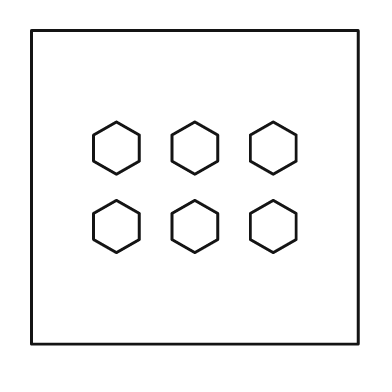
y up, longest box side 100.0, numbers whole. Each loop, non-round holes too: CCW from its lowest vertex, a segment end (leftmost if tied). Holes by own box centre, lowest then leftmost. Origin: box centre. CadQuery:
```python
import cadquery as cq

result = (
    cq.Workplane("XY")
    .moveTo(-50.0, -48.0)
    .lineTo(50.0, -48.0)
    .lineTo(50.0, 48.0)
    .lineTo(-50.0, 48.0)
    .close()
    .moveTo(-24.0, -20.0)
    .lineTo(-17.0, -16.0)
    .lineTo(-17.0, -8.0)
    .lineTo(-24.0, -4.0)
    .lineTo(-31.0, -8.0)
    .lineTo(-31.0, -16.0)
    .close()
    .moveTo(0.0, -20.0)
    .lineTo(7.0, -16.0)
    .lineTo(7.0, -8.0)
    .lineTo(0.0, -4.0)
    .lineTo(-7.0, -8.0)
    .lineTo(-7.0, -16.0)
    .close()
    .moveTo(24.0, -20.0)
    .lineTo(31.0, -16.0)
    .lineTo(31.0, -8.0)
    .lineTo(24.0, -4.0)
    .lineTo(17.0, -8.0)
    .lineTo(17.0, -16.0)
    .close()
    .moveTo(-24.0, 4.0)
    .lineTo(-17.0, 8.0)
    .lineTo(-17.0, 16.0)
    .lineTo(-24.0, 20.0)
    .lineTo(-31.0, 16.0)
    .lineTo(-31.0, 8.0)
    .close()
    .moveTo(0.0, 4.0)
    .lineTo(7.0, 8.0)
    .lineTo(7.0, 16.0)
    .lineTo(0.0, 20.0)
    .lineTo(-7.0, 16.0)
    .lineTo(-7.0, 8.0)
    .close()
    .moveTo(24.0, 4.0)
    .lineTo(31.0, 8.0)
    .lineTo(31.0, 16.0)
    .lineTo(24.0, 20.0)
    .lineTo(17.0, 16.0)
    .lineTo(17.0, 8.0)
    .close()
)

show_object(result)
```